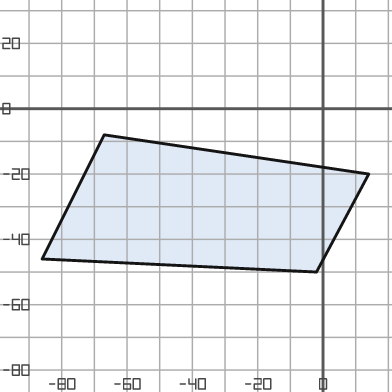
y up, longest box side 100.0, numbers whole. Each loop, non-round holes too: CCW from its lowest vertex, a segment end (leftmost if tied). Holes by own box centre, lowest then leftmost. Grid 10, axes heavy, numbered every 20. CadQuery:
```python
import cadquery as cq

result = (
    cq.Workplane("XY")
    .moveTo(-2.0, -50.0)
    .lineTo(14.0, -20.0)
    .lineTo(-67.0, -8.0)
    .lineTo(-86.0, -46.0)
    .close()
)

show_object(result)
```